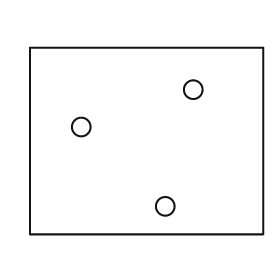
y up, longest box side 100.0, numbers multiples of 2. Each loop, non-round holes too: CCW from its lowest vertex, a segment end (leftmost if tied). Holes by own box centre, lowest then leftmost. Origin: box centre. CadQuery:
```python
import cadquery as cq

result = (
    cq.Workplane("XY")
    .moveTo(-50.0, -40.0)
    .lineTo(50.0, -40.0)
    .lineTo(50.0, 40.0)
    .lineTo(-50.0, 40.0)
    .close()
    .moveTo(8.0, -28.0)
    .circle(4.0)
    .moveTo(-28.0, 6.0)
    .circle(4.0)
    .moveTo(20.0, 22.0)
    .circle(4.0)
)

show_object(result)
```